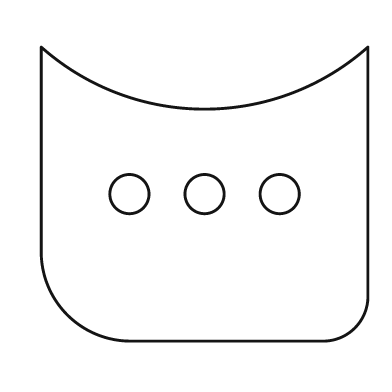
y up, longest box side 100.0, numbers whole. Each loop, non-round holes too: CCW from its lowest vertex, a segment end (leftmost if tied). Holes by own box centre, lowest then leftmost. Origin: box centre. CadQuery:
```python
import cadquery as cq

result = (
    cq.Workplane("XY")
    .moveTo(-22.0, -45.0)
    .lineTo(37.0, -45.0)
    .threePointArc((46.0, -41.0), (50.0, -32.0))
    .lineTo(50.0, 45.0)
    .threePointArc((0.0, 26.0), (-50.0, 45.0))
    .lineTo(-50.0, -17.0)
    .threePointArc((-42.0, -37.0), (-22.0, -45.0))
    .close()
    .moveTo(-23.0, 0.0)
    .circle(6.0)
    .moveTo(0.0, 0.0)
    .circle(6.0)
    .moveTo(23.0, 0.0)
    .circle(6.0)
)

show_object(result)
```